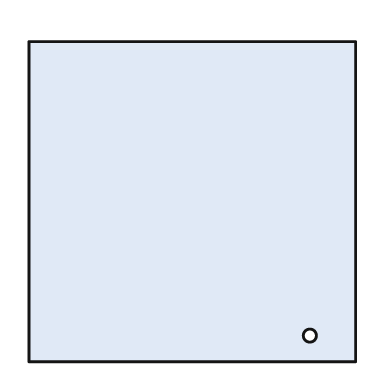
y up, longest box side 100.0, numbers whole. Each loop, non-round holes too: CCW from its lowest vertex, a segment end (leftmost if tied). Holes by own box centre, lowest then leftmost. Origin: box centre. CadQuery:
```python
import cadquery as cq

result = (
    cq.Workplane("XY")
    .moveTo(-50.0, -49.0)
    .lineTo(50.0, -49.0)
    .lineTo(50.0, 49.0)
    .lineTo(-50.0, 49.0)
    .close()
    .moveTo(36.0, -41.0)
    .circle(2.0)
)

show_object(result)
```